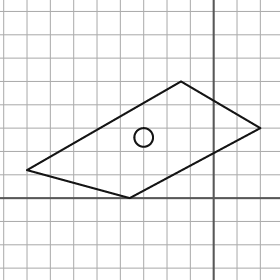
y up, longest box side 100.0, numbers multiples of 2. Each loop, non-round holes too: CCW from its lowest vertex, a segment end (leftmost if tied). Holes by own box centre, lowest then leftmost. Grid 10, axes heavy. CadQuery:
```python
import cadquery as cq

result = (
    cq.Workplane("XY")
    .moveTo(-36.0, 0.0)
    .lineTo(20.0, 30.0)
    .lineTo(-14.0, 50.0)
    .lineTo(-80.0, 12.0)
    .close()
    .moveTo(-30.0, 26.0)
    .circle(4.0)
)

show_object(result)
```